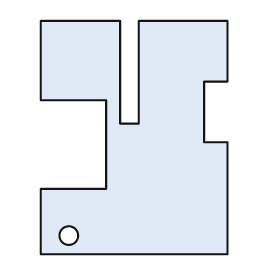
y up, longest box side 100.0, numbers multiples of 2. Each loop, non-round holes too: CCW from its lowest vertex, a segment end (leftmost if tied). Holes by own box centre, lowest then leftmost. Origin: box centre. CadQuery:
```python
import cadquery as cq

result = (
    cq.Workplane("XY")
    .moveTo(-40.0, -50.0)
    .lineTo(40.0, -50.0)
    .lineTo(40.0, -2.0)
    .lineTo(30.0, -2.0)
    .lineTo(30.0, 24.0)
    .lineTo(40.0, 24.0)
    .lineTo(40.0, 50.0)
    .lineTo(2.0, 50.0)
    .lineTo(2.0, 6.0)
    .lineTo(-6.0, 6.0)
    .lineTo(-6.0, 50.0)
    .lineTo(-40.0, 50.0)
    .lineTo(-40.0, 16.0)
    .lineTo(-12.0, 16.0)
    .lineTo(-12.0, -22.0)
    .lineTo(-40.0, -22.0)
    .close()
    .moveTo(-28.0, -42.0)
    .circle(4.0)
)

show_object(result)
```